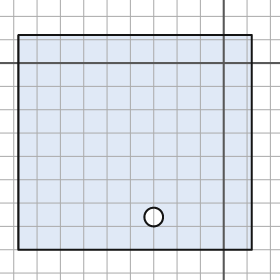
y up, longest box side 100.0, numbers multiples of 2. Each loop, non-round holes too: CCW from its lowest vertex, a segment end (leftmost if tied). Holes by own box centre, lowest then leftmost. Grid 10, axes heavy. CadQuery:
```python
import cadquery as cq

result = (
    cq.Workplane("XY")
    .moveTo(-88.0, -80.0)
    .lineTo(12.0, -80.0)
    .lineTo(12.0, 12.0)
    .lineTo(-88.0, 12.0)
    .close()
    .moveTo(-30.0, -66.0)
    .circle(4.0)
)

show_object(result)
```